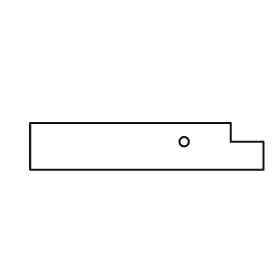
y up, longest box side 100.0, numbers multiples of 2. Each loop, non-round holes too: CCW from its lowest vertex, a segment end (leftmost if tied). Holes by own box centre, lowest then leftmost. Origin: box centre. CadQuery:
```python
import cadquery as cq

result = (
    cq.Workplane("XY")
    .moveTo(-50.0, -10.0)
    .lineTo(50.0, -10.0)
    .lineTo(50.0, 2.0)
    .lineTo(36.0, 2.0)
    .lineTo(36.0, 10.0)
    .lineTo(-50.0, 10.0)
    .close()
    .moveTo(16.0, 2.0)
    .circle(2.0)
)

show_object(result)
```